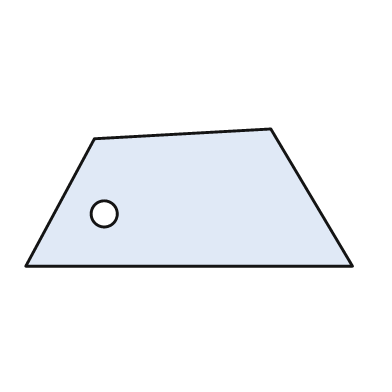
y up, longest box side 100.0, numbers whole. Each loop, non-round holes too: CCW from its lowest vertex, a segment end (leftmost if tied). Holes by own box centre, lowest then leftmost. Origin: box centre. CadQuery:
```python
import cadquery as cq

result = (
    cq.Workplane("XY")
    .moveTo(-50.0, -21.0)
    .lineTo(50.0, -21.0)
    .lineTo(25.0, 21.0)
    .lineTo(-29.0, 18.0)
    .close()
    .moveTo(-26.0, -5.0)
    .circle(4.0)
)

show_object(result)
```